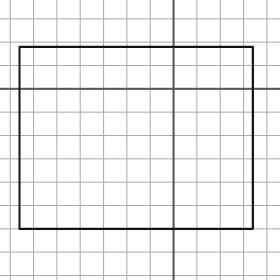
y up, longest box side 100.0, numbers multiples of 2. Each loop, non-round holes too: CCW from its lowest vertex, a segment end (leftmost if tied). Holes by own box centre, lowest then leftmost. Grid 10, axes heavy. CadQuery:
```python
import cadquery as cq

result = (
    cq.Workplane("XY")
    .moveTo(-66.0, -60.0)
    .lineTo(34.0, -60.0)
    .lineTo(34.0, 18.0)
    .lineTo(-66.0, 18.0)
    .close()
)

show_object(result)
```